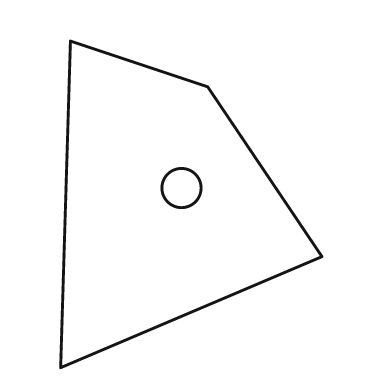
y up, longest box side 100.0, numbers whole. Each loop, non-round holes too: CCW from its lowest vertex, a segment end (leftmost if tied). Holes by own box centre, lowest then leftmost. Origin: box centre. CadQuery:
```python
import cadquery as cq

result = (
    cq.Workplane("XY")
    .moveTo(-40.0, -50.0)
    .lineTo(40.0, -16.0)
    .lineTo(5.0, 36.0)
    .lineTo(-37.0, 50.0)
    .close()
    .moveTo(-3.0, 5.0)
    .circle(6.0)
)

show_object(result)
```